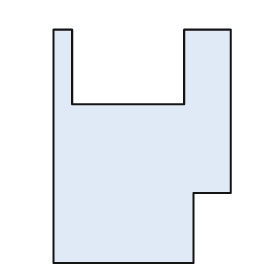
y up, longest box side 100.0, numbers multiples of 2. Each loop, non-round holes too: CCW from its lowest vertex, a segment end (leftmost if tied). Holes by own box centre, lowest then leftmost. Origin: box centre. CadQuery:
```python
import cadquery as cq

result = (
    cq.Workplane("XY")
    .moveTo(-38.0, -50.0)
    .lineTo(22.0, -50.0)
    .lineTo(22.0, -20.0)
    .lineTo(38.0, -20.0)
    .lineTo(38.0, 50.0)
    .lineTo(18.0, 50.0)
    .lineTo(18.0, 18.0)
    .lineTo(-30.0, 18.0)
    .lineTo(-30.0, 50.0)
    .lineTo(-38.0, 50.0)
    .close()
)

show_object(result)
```